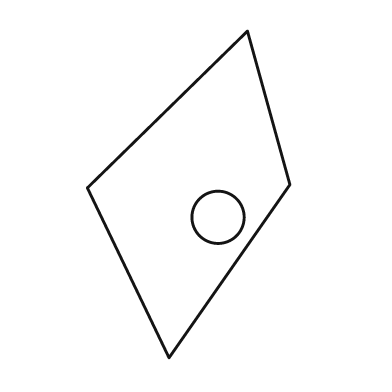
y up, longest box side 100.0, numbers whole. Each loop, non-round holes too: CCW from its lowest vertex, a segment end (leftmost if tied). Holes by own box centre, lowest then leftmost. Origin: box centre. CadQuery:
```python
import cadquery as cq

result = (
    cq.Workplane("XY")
    .moveTo(-6.0, -50.0)
    .lineTo(31.0, 3.0)
    .lineTo(18.0, 50.0)
    .lineTo(-31.0, 2.0)
    .close()
    .moveTo(9.0, -7.0)
    .circle(8.0)
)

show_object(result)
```